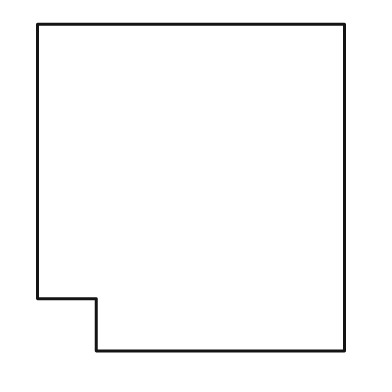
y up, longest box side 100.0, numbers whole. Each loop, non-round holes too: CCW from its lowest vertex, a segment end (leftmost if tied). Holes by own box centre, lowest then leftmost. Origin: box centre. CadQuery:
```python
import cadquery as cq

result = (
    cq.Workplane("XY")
    .moveTo(-29.0, -50.0)
    .lineTo(47.0, -50.0)
    .lineTo(47.0, 50.0)
    .lineTo(-47.0, 50.0)
    .lineTo(-47.0, -34.0)
    .lineTo(-29.0, -34.0)
    .close()
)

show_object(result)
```